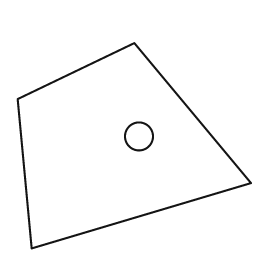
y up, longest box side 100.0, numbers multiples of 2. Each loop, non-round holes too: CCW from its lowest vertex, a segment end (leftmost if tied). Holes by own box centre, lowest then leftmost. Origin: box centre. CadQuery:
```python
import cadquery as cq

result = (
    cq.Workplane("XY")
    .moveTo(-44.0, -44.0)
    .lineTo(50.0, -16.0)
    .lineTo(0.0, 44.0)
    .lineTo(-50.0, 20.0)
    .close()
    .moveTo(2.0, 4.0)
    .circle(6.0)
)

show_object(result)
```